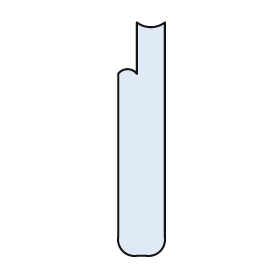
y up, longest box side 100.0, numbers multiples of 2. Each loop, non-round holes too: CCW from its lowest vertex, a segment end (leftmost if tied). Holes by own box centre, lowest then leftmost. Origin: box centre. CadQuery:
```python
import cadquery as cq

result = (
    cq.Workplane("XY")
    .moveTo(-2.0, -50.0)
    .lineTo(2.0, -50.0)
    .threePointArc((8.0, -48.0), (10.0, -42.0))
    .lineTo(10.0, 50.0)
    .threePointArc((4.0, 48.0), (-2.0, 50.0))
    .lineTo(-2.0, 28.0)
    .threePointArc((-6.0, 30.0), (-10.0, 28.0))
    .lineTo(-10.0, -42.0)
    .threePointArc((-8.0, -48.0), (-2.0, -50.0))
    .close()
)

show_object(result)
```